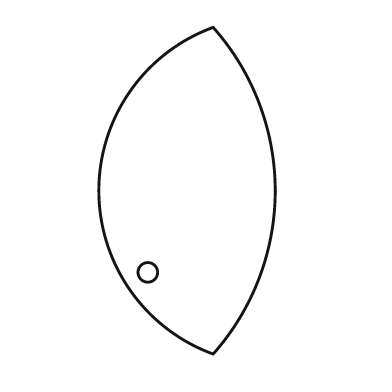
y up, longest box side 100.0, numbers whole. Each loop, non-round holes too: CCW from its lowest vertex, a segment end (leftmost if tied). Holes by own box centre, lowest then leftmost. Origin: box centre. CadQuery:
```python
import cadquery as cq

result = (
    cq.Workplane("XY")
    .moveTo(8.0, -50.0)
    .threePointArc((27.0, 0.0), (8.0, 50.0))
    .threePointArc((-27.0, 0.0), (8.0, -50.0))
    .close()
    .moveTo(-12.0, -25.0)
    .circle(3.0)
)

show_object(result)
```